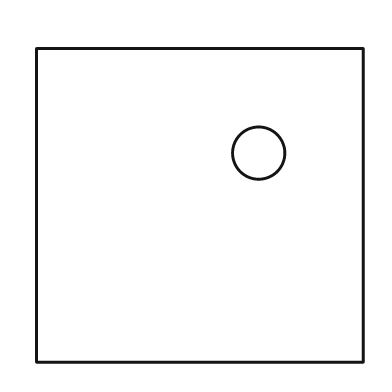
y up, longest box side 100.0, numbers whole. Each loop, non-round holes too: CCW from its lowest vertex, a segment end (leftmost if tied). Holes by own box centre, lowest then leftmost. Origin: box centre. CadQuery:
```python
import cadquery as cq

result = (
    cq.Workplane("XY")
    .moveTo(-50.0, -48.0)
    .lineTo(50.0, -48.0)
    .lineTo(50.0, 48.0)
    .lineTo(-50.0, 48.0)
    .close()
    .moveTo(18.0, 16.0)
    .circle(8.0)
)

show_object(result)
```